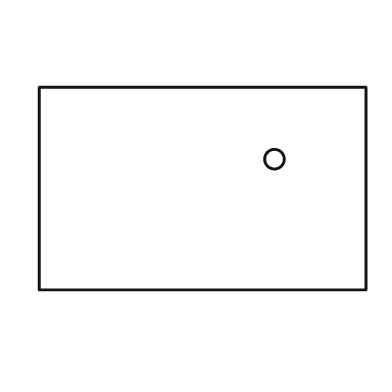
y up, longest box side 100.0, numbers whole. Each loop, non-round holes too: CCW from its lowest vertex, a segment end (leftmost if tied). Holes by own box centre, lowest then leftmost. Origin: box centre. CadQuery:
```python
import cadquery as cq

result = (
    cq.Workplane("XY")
    .moveTo(-50.0, -31.0)
    .lineTo(50.0, -31.0)
    .lineTo(50.0, 31.0)
    .lineTo(-50.0, 31.0)
    .close()
    .moveTo(22.0, 9.0)
    .circle(3.0)
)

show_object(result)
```